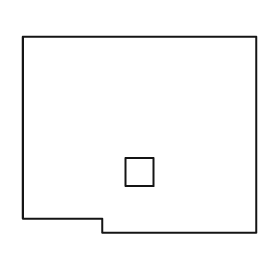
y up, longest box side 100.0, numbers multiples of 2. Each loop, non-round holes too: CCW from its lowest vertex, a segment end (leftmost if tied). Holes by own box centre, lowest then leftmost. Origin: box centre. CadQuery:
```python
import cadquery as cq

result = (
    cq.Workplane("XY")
    .moveTo(-16.0, -42.0)
    .lineTo(50.0, -42.0)
    .lineTo(50.0, 42.0)
    .lineTo(-50.0, 42.0)
    .lineTo(-50.0, -36.0)
    .lineTo(-16.0, -36.0)
    .close()
    .moveTo(-6.0, -22.0)
    .lineTo(6.0, -22.0)
    .lineTo(6.0, -10.0)
    .lineTo(-6.0, -10.0)
    .close()
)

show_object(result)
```